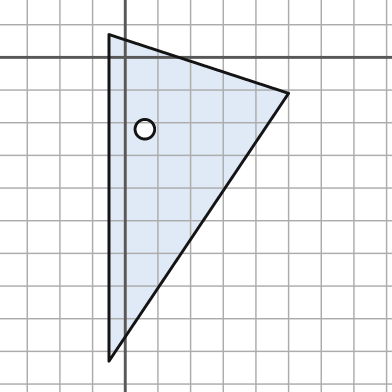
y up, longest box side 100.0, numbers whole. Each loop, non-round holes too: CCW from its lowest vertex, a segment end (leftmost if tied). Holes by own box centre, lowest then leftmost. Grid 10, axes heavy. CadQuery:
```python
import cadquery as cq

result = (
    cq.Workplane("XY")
    .moveTo(-5.0, -93.0)
    .lineTo(50.0, -11.0)
    .lineTo(-5.0, 7.0)
    .close()
    .moveTo(6.0, -22.0)
    .circle(3.0)
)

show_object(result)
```